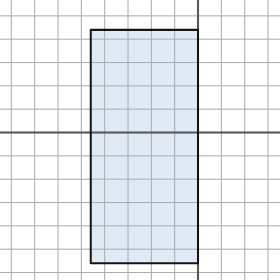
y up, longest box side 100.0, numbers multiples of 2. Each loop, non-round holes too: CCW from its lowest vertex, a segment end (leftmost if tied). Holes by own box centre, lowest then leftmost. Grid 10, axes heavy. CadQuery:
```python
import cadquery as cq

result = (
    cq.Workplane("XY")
    .moveTo(-46.0, -56.0)
    .lineTo(0.0, -56.0)
    .lineTo(0.0, 44.0)
    .lineTo(-46.0, 44.0)
    .close()
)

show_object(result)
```